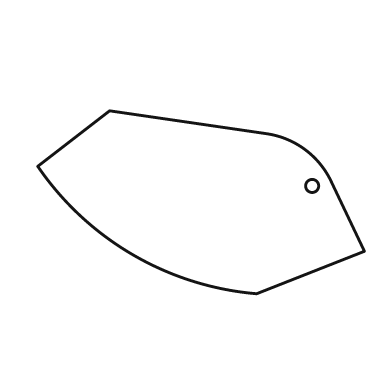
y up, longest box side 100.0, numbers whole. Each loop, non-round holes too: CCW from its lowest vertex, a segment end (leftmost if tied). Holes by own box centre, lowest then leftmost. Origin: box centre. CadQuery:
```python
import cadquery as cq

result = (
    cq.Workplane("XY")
    .moveTo(17.0, -28.0)
    .lineTo(50.0, -15.0)
    .lineTo(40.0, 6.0)
    .threePointArc((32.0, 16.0), (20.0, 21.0))
    .lineTo(-28.0, 28.0)
    .lineTo(-50.0, 11.0)
    .threePointArc((-21.0, -16.0), (17.0, -28.0))
    .close()
    .moveTo(34.0, 5.0)
    .circle(2.0)
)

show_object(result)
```